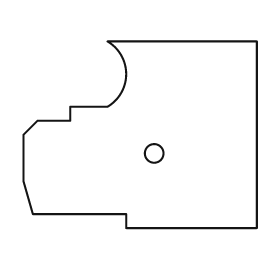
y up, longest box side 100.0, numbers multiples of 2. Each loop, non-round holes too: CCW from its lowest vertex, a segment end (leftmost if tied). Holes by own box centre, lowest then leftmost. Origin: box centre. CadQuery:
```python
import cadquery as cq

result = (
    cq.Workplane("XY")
    .moveTo(-6.0, -40.0)
    .lineTo(50.0, -40.0)
    .lineTo(50.0, 40.0)
    .lineTo(-14.0, 40.0)
    .threePointArc((-6.0, 26.0), (-14.0, 12.0))
    .lineTo(-30.0, 12.0)
    .lineTo(-30.0, 6.0)
    .lineTo(-44.0, 6.0)
    .lineTo(-50.0, 0.0)
    .lineTo(-50.0, -20.0)
    .lineTo(-46.0, -34.0)
    .lineTo(-6.0, -34.0)
    .close()
    .moveTo(6.0, -8.0)
    .circle(4.0)
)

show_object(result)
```